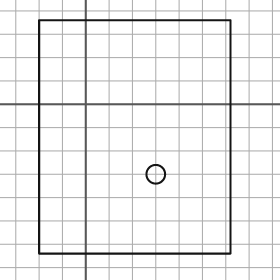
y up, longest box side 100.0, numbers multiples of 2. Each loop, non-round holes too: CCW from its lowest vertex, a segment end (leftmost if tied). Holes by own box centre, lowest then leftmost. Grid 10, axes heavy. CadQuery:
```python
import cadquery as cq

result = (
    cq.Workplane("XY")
    .moveTo(-20.0, -64.0)
    .lineTo(62.0, -64.0)
    .lineTo(62.0, 36.0)
    .lineTo(-20.0, 36.0)
    .close()
    .moveTo(30.0, -30.0)
    .circle(4.0)
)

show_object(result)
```